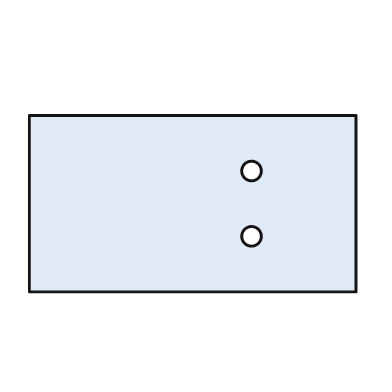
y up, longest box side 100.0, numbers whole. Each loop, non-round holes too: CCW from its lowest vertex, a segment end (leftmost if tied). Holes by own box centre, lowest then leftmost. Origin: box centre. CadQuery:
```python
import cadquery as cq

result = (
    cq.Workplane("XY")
    .moveTo(-50.0, -27.0)
    .lineTo(50.0, -27.0)
    .lineTo(50.0, 27.0)
    .lineTo(-50.0, 27.0)
    .close()
    .moveTo(18.0, -10.0)
    .circle(3.0)
    .moveTo(18.0, 10.0)
    .circle(3.0)
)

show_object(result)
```